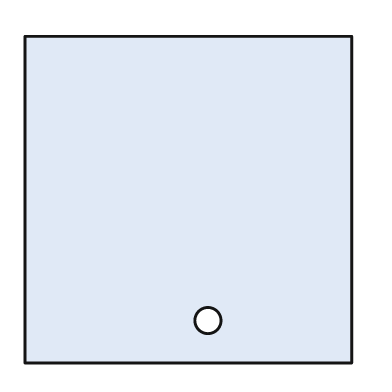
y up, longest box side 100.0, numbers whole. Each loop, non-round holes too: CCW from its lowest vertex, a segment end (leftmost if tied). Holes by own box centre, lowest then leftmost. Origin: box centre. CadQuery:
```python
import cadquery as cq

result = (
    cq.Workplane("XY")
    .moveTo(-50.0, -50.0)
    .lineTo(50.0, -50.0)
    .lineTo(50.0, 50.0)
    .lineTo(-50.0, 50.0)
    .close()
    .moveTo(6.0, -37.0)
    .circle(4.0)
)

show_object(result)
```